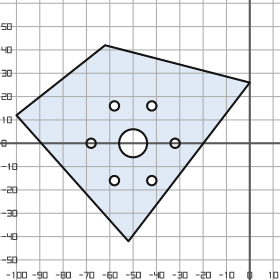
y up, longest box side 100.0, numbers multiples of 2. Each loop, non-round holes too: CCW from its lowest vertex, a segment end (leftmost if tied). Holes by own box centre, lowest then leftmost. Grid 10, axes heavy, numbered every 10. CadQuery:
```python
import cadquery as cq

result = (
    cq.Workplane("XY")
    .moveTo(-52.0, -42.0)
    .lineTo(0.0, 26.0)
    .lineTo(-62.0, 42.0)
    .lineTo(-100.0, 12.0)
    .close()
    .moveTo(-58.0, -16.0)
    .circle(2.0)
    .moveTo(-42.0, -16.0)
    .circle(2.0)
    .moveTo(-68.0, 0.0)
    .circle(2.0)
    .moveTo(-50.0, 0.0)
    .circle(6.0)
    .moveTo(-32.0, 0.0)
    .circle(2.0)
    .moveTo(-58.0, 16.0)
    .circle(2.0)
    .moveTo(-42.0, 16.0)
    .circle(2.0)
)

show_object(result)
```